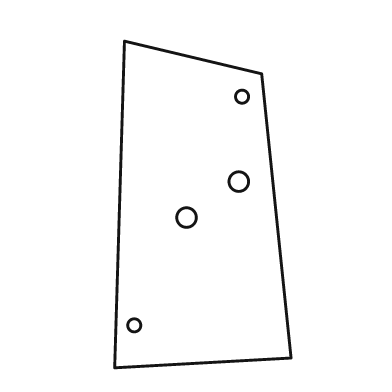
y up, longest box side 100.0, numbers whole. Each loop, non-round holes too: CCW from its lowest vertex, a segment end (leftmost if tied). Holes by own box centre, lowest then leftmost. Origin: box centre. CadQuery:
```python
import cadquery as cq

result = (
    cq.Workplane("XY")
    .moveTo(-27.0, -50.0)
    .lineTo(27.0, -47.0)
    .lineTo(18.0, 40.0)
    .lineTo(-24.0, 50.0)
    .close()
    .moveTo(-21.0, -37.0)
    .circle(2.0)
    .moveTo(-5.0, -4.0)
    .circle(3.0)
    .moveTo(11.0, 7.0)
    .circle(3.0)
    .moveTo(12.0, 33.0)
    .circle(2.0)
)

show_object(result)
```